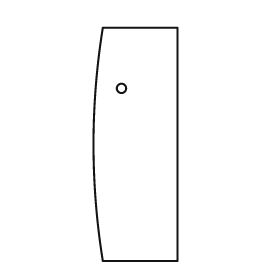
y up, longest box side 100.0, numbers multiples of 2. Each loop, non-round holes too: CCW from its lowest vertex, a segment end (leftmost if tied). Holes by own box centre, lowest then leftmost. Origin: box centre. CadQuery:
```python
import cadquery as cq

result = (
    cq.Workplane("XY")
    .moveTo(-14.0, -50.0)
    .lineTo(18.0, -50.0)
    .lineTo(18.0, 50.0)
    .lineTo(-14.0, 50.0)
    .threePointArc((-18.0, 0.0), (-14.0, -50.0))
    .close()
    .moveTo(-6.0, 24.0)
    .circle(2.0)
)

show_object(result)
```